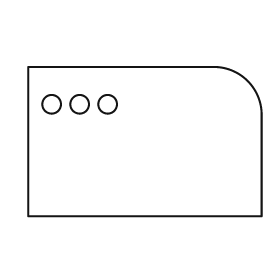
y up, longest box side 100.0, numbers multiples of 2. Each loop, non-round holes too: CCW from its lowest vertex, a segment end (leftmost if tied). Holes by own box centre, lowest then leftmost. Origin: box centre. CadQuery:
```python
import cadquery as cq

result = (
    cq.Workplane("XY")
    .moveTo(-50.0, -32.0)
    .lineTo(50.0, -32.0)
    .lineTo(50.0, 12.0)
    .threePointArc((44.0, 26.0), (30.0, 32.0))
    .lineTo(-50.0, 32.0)
    .close()
    .moveTo(-40.0, 16.0)
    .circle(4.0)
    .moveTo(-28.0, 16.0)
    .circle(4.0)
    .moveTo(-16.0, 16.0)
    .circle(4.0)
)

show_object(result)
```